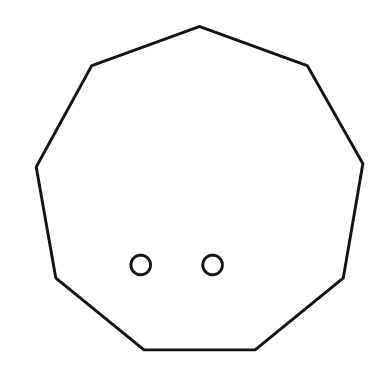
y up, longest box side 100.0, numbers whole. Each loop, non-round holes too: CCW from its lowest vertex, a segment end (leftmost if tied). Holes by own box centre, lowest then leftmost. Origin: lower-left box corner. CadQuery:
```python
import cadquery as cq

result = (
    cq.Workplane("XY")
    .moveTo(33.0, 0.0)
    .lineTo(67.0, 0.0)
    .lineTo(94.0, 22.0)
    .lineTo(100.0, 57.0)
    .lineTo(83.0, 87.0)
    .lineTo(50.0, 99.0)
    .lineTo(17.0, 87.0)
    .lineTo(0.0, 56.0)
    .lineTo(6.0, 22.0)
    .close()
    .moveTo(32.0, 26.0)
    .circle(3.0)
    .moveTo(54.0, 26.0)
    .circle(3.0)
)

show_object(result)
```